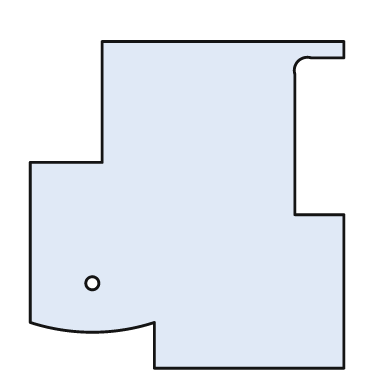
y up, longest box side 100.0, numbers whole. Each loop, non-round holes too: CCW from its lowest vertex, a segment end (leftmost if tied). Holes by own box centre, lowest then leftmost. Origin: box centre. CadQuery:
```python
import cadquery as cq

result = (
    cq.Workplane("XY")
    .moveTo(-10.0, -50.0)
    .lineTo(48.0, -50.0)
    .lineTo(48.0, -3.0)
    .lineTo(33.0, -3.0)
    .lineTo(33.0, 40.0)
    .threePointArc((34.0, 44.0), (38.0, 45.0))
    .lineTo(48.0, 45.0)
    .lineTo(48.0, 50.0)
    .lineTo(-26.0, 50.0)
    .lineTo(-26.0, 13.0)
    .lineTo(-48.0, 13.0)
    .lineTo(-48.0, -36.0)
    .threePointArc((-29.0, -39.0), (-10.0, -36.0))
    .close()
    .moveTo(-29.0, -24.0)
    .circle(2.0)
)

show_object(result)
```